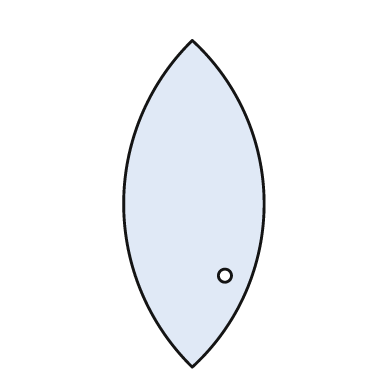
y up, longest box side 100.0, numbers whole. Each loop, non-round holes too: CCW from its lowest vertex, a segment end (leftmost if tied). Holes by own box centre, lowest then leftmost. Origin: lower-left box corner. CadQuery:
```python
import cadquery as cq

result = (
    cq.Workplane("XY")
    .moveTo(21.0, 0.0)
    .threePointArc((43.0, 50.0), (21.0, 100.0))
    .threePointArc((0.0, 50.0), (21.0, 0.0))
    .close()
    .moveTo(31.0, 28.0)
    .circle(2.0)
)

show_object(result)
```